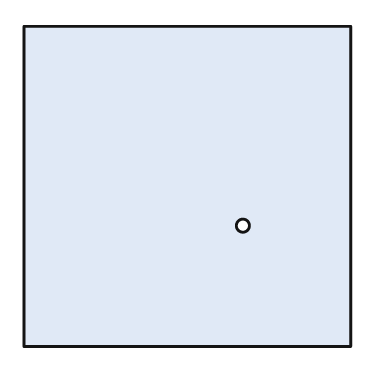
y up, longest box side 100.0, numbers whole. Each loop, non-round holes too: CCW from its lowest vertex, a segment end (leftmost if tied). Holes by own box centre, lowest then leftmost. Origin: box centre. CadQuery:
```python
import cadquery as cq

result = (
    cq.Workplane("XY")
    .moveTo(-50.0, -49.0)
    .lineTo(50.0, -49.0)
    .lineTo(50.0, 49.0)
    .lineTo(-50.0, 49.0)
    .close()
    .moveTo(17.0, -12.0)
    .circle(2.0)
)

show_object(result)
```